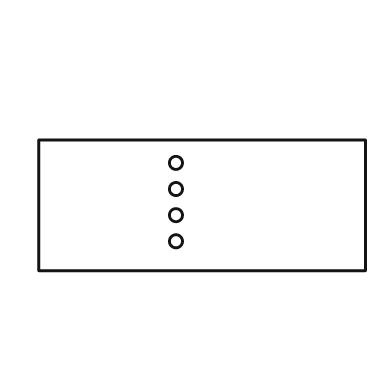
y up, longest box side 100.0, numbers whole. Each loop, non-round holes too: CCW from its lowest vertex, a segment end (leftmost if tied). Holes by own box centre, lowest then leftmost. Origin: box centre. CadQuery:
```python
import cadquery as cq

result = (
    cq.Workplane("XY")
    .moveTo(-50.0, -20.0)
    .lineTo(50.0, -20.0)
    .lineTo(50.0, 20.0)
    .lineTo(-50.0, 20.0)
    .close()
    .moveTo(-8.0, -11.0)
    .circle(2.0)
    .moveTo(-8.0, -3.0)
    .circle(2.0)
    .moveTo(-8.0, 5.0)
    .circle(2.0)
    .moveTo(-8.0, 13.0)
    .circle(2.0)
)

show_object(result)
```